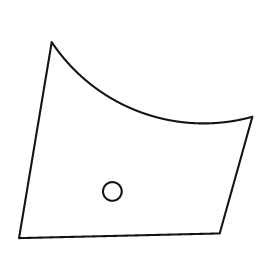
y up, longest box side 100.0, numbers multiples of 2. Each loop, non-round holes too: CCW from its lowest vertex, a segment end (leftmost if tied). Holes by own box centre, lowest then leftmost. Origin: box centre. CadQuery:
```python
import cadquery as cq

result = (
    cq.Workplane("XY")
    .moveTo(-50.0, -42.0)
    .lineTo(36.0, -40.0)
    .lineTo(50.0, 10.0)
    .threePointArc((2.0, 12.0), (-36.0, 42.0))
    .close()
    .moveTo(-10.0, -22.0)
    .circle(4.0)
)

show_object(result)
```